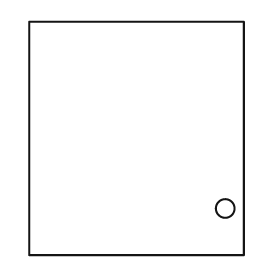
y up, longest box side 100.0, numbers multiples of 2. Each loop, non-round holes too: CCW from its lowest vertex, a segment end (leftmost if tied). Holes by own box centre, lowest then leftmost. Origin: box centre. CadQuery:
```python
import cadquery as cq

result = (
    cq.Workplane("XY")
    .moveTo(-46.0, -50.0)
    .lineTo(46.0, -50.0)
    .lineTo(46.0, 50.0)
    .lineTo(-46.0, 50.0)
    .close()
    .moveTo(38.0, -30.0)
    .circle(4.0)
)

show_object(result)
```